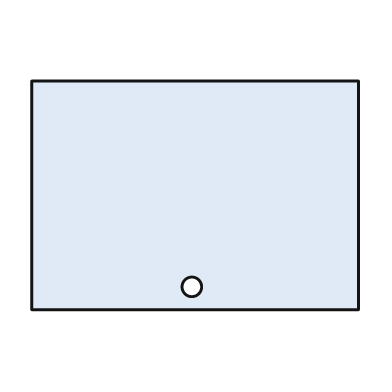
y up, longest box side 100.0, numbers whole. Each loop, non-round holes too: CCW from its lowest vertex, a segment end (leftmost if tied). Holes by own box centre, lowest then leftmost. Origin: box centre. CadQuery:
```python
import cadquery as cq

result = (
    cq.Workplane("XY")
    .moveTo(-50.0, -35.0)
    .lineTo(50.0, -35.0)
    .lineTo(50.0, 35.0)
    .lineTo(-50.0, 35.0)
    .close()
    .moveTo(-1.0, -28.0)
    .circle(3.0)
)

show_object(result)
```